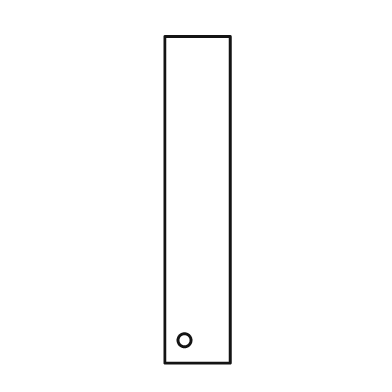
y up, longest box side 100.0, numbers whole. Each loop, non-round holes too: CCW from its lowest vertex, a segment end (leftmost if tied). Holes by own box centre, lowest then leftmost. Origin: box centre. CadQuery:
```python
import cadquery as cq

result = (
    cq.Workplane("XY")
    .moveTo(-10.0, -50.0)
    .lineTo(10.0, -50.0)
    .lineTo(10.0, 50.0)
    .lineTo(-10.0, 50.0)
    .close()
    .moveTo(-4.0, -43.0)
    .circle(2.0)
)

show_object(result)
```